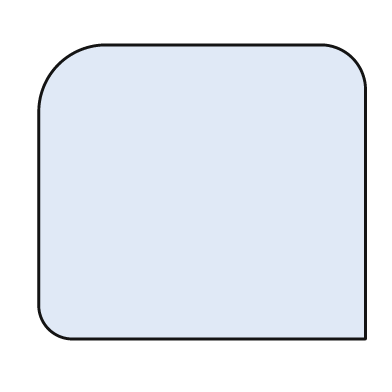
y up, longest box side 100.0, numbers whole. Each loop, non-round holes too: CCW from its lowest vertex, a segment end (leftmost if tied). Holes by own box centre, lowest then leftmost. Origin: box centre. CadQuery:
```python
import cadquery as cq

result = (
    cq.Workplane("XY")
    .moveTo(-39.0, -45.0)
    .lineTo(50.0, -45.0)
    .lineTo(50.0, 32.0)
    .threePointArc((46.0, 41.0), (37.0, 45.0))
    .lineTo(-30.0, 45.0)
    .threePointArc((-44.0, 39.0), (-50.0, 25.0))
    .lineTo(-50.0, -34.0)
    .threePointArc((-47.0, -42.0), (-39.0, -45.0))
    .close()
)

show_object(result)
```